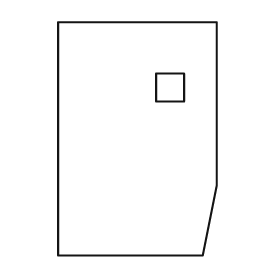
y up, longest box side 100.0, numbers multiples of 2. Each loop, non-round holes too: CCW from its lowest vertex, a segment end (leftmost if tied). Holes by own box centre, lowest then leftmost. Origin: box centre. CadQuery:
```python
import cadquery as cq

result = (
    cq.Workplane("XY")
    .moveTo(-34.0, -50.0)
    .lineTo(28.0, -50.0)
    .lineTo(34.0, -20.0)
    .lineTo(34.0, 50.0)
    .lineTo(-34.0, 50.0)
    .close()
    .moveTo(8.0, 16.0)
    .lineTo(20.0, 16.0)
    .lineTo(20.0, 28.0)
    .lineTo(8.0, 28.0)
    .close()
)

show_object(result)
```